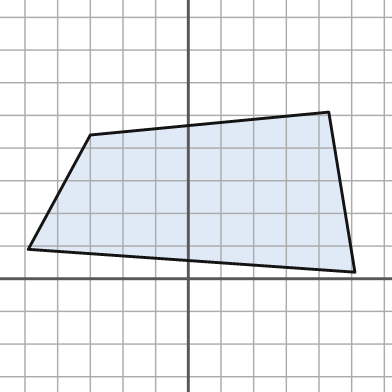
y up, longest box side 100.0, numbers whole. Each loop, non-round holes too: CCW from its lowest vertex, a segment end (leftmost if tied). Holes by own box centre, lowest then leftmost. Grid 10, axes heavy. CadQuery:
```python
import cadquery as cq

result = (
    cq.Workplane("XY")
    .moveTo(51.0, 2.0)
    .lineTo(43.0, 51.0)
    .lineTo(-30.0, 44.0)
    .lineTo(-49.0, 9.0)
    .close()
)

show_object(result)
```